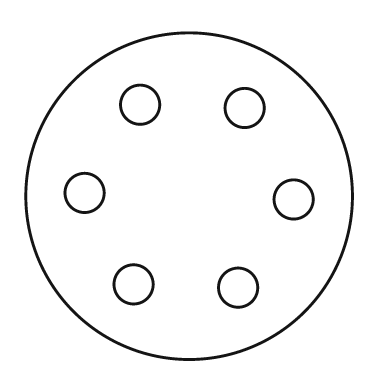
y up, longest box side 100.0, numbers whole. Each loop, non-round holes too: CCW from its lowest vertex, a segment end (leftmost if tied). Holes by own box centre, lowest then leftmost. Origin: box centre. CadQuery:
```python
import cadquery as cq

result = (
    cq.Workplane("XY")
    .moveTo(0.0, 0.0)
    .circle(50.0)
    .moveTo(15.0, -28.0)
    .circle(6.0)
    .moveTo(-17.0, -27.0)
    .circle(6.0)
    .moveTo(32.0, -1.0)
    .circle(6.0)
    .moveTo(-32.0, 1.0)
    .circle(6.0)
    .moveTo(17.0, 27.0)
    .circle(6.0)
    .moveTo(-15.0, 28.0)
    .circle(6.0)
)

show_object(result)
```